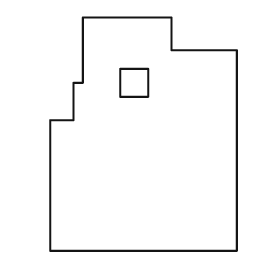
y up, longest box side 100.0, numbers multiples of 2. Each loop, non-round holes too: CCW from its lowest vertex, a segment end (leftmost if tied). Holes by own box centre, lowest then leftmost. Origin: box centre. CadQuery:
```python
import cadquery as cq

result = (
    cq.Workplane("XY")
    .moveTo(-40.0, -50.0)
    .lineTo(40.0, -50.0)
    .lineTo(40.0, 36.0)
    .lineTo(12.0, 36.0)
    .lineTo(12.0, 50.0)
    .lineTo(-26.0, 50.0)
    .lineTo(-26.0, 22.0)
    .lineTo(-30.0, 22.0)
    .lineTo(-30.0, 6.0)
    .lineTo(-40.0, 6.0)
    .close()
    .moveTo(-10.0, 16.0)
    .lineTo(2.0, 16.0)
    .lineTo(2.0, 28.0)
    .lineTo(-10.0, 28.0)
    .close()
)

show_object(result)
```